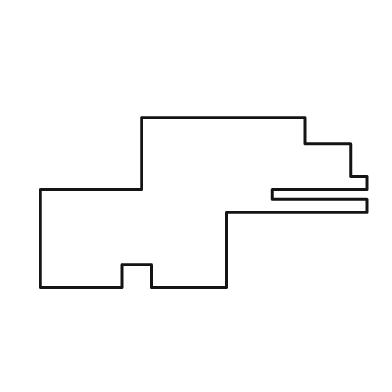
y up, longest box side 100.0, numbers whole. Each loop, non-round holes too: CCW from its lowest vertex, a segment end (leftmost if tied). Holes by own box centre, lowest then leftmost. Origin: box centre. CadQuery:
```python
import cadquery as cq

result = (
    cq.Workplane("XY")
    .moveTo(-50.0, -26.0)
    .lineTo(-25.0, -26.0)
    .lineTo(-25.0, -19.0)
    .lineTo(-16.0, -19.0)
    .lineTo(-16.0, -26.0)
    .lineTo(7.0, -26.0)
    .lineTo(7.0, -3.0)
    .lineTo(50.0, -3.0)
    .lineTo(50.0, 1.0)
    .lineTo(21.0, 1.0)
    .lineTo(21.0, 4.0)
    .lineTo(50.0, 4.0)
    .lineTo(50.0, 8.0)
    .lineTo(45.0, 8.0)
    .lineTo(45.0, 18.0)
    .lineTo(31.0, 18.0)
    .lineTo(31.0, 26.0)
    .lineTo(-19.0, 26.0)
    .lineTo(-19.0, 4.0)
    .lineTo(-50.0, 4.0)
    .close()
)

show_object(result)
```